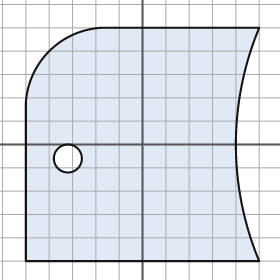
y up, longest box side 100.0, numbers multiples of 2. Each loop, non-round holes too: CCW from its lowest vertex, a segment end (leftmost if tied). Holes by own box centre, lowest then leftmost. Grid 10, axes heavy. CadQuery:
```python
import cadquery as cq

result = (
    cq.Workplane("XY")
    .moveTo(-50.0, -50.0)
    .lineTo(50.0, -50.0)
    .threePointArc((40.0, 0.0), (50.0, 50.0))
    .lineTo(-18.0, 50.0)
    .threePointArc((-40.0, 40.0), (-50.0, 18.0))
    .close()
    .moveTo(-32.0, -6.0)
    .circle(6.0)
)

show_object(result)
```